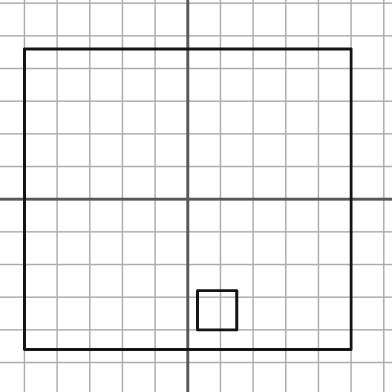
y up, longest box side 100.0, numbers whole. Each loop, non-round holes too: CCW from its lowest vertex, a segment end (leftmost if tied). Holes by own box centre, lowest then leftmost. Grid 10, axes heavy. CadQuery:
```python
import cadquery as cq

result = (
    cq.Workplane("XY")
    .moveTo(-50.0, -46.0)
    .lineTo(50.0, -46.0)
    .lineTo(50.0, 46.0)
    .lineTo(-50.0, 46.0)
    .close()
    .moveTo(3.0, -40.0)
    .lineTo(15.0, -40.0)
    .lineTo(15.0, -28.0)
    .lineTo(3.0, -28.0)
    .close()
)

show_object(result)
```